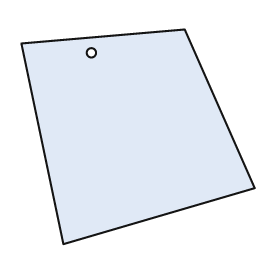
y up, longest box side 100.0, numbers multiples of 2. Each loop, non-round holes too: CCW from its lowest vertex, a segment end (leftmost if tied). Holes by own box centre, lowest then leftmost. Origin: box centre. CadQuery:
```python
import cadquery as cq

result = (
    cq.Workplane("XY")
    .moveTo(-32.0, -46.0)
    .lineTo(50.0, -22.0)
    .lineTo(20.0, 46.0)
    .lineTo(-50.0, 40.0)
    .close()
    .moveTo(-20.0, 36.0)
    .circle(2.0)
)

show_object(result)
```